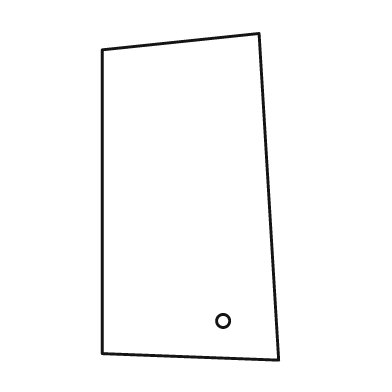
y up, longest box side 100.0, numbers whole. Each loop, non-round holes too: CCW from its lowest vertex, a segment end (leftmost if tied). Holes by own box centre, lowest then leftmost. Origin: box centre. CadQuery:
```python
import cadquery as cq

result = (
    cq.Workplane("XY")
    .moveTo(27.0, -50.0)
    .lineTo(21.0, 50.0)
    .lineTo(-27.0, 45.0)
    .lineTo(-27.0, -48.0)
    .close()
    .moveTo(10.0, -38.0)
    .circle(2.0)
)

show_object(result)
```